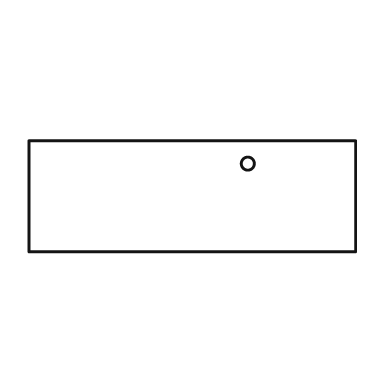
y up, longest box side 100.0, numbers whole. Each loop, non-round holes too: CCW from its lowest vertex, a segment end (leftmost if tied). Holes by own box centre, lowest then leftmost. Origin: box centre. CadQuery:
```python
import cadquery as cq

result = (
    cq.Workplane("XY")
    .moveTo(-50.0, -17.0)
    .lineTo(50.0, -17.0)
    .lineTo(50.0, 17.0)
    .lineTo(-50.0, 17.0)
    .close()
    .moveTo(17.0, 10.0)
    .circle(2.0)
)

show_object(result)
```